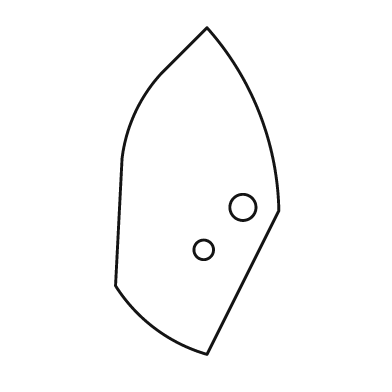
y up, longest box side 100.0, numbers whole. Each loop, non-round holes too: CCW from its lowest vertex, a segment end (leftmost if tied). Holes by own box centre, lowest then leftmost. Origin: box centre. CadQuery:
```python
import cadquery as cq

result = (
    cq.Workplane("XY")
    .moveTo(3.0, -50.0)
    .lineTo(25.0, -6.0)
    .threePointArc((19.0, 24.0), (3.0, 50.0))
    .lineTo(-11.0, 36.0)
    .threePointArc((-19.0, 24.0), (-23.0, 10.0))
    .lineTo(-25.0, -29.0)
    .threePointArc((-13.0, -42.0), (3.0, -50.0))
    .close()
    .moveTo(2.0, -18.0)
    .circle(3.0)
    .moveTo(14.0, -5.0)
    .circle(4.0)
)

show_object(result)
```